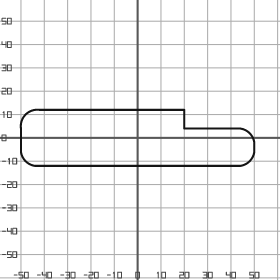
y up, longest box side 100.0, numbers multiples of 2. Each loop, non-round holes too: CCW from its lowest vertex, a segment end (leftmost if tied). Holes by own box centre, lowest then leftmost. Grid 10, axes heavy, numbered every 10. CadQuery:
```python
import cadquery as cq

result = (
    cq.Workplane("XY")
    .moveTo(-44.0, -12.0)
    .lineTo(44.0, -12.0)
    .threePointArc((48.0, -10.0), (50.0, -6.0))
    .lineTo(50.0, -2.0)
    .threePointArc((48.0, 2.0), (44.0, 4.0))
    .lineTo(20.0, 4.0)
    .lineTo(20.0, 12.0)
    .lineTo(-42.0, 12.0)
    .threePointArc((-48.0, 10.0), (-50.0, 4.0))
    .lineTo(-50.0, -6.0)
    .threePointArc((-48.0, -10.0), (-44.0, -12.0))
    .close()
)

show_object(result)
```